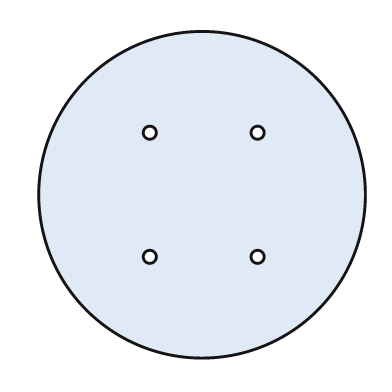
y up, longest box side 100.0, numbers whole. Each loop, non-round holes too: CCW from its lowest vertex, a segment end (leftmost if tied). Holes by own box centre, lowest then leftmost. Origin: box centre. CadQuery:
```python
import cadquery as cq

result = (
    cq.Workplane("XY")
    .moveTo(0.0, 0.0)
    .circle(50.0)
    .moveTo(-16.0, -19.0)
    .circle(2.0)
    .moveTo(17.0, -19.0)
    .circle(2.0)
    .moveTo(-16.0, 19.0)
    .circle(2.0)
    .moveTo(17.0, 19.0)
    .circle(2.0)
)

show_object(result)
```